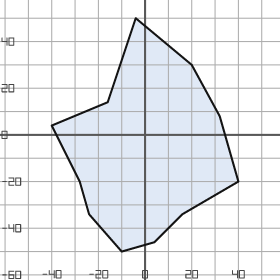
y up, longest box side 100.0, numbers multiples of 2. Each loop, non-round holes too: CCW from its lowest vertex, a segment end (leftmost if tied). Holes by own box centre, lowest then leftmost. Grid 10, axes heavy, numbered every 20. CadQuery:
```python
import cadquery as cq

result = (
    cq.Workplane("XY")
    .moveTo(-10.0, -50.0)
    .lineTo(4.0, -46.0)
    .lineTo(16.0, -34.0)
    .lineTo(40.0, -20.0)
    .lineTo(32.0, 8.0)
    .lineTo(20.0, 30.0)
    .lineTo(-4.0, 50.0)
    .lineTo(-16.0, 14.0)
    .lineTo(-40.0, 4.0)
    .lineTo(-28.0, -20.0)
    .lineTo(-24.0, -34.0)
    .close()
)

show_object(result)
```